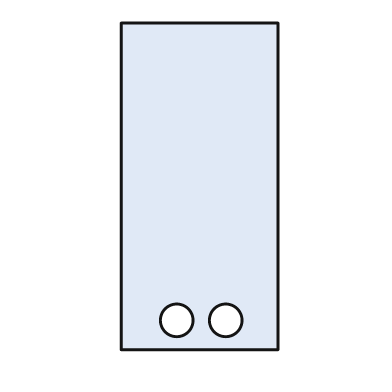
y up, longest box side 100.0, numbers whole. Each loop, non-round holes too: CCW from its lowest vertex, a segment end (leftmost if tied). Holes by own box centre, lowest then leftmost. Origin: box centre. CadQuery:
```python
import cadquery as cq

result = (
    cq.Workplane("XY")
    .moveTo(-24.0, -50.0)
    .lineTo(24.0, -50.0)
    .lineTo(24.0, 50.0)
    .lineTo(-24.0, 50.0)
    .close()
    .moveTo(-7.0, -41.0)
    .circle(5.0)
    .moveTo(8.0, -41.0)
    .circle(5.0)
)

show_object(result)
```